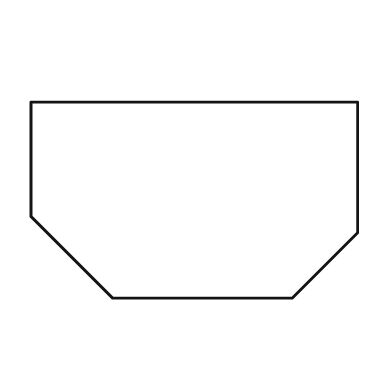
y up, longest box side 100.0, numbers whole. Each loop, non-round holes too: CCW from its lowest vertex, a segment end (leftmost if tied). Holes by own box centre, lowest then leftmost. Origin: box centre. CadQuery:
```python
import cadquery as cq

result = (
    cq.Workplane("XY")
    .moveTo(-25.0, -30.0)
    .lineTo(30.0, -30.0)
    .lineTo(50.0, -10.0)
    .lineTo(50.0, 30.0)
    .lineTo(-50.0, 30.0)
    .lineTo(-50.0, -5.0)
    .close()
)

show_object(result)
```